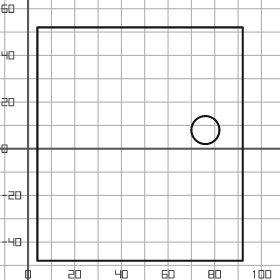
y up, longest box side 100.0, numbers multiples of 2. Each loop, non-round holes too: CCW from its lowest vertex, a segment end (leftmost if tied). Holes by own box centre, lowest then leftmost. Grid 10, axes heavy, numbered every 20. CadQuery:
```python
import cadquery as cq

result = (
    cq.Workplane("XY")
    .moveTo(4.0, -48.0)
    .lineTo(92.0, -48.0)
    .lineTo(92.0, 52.0)
    .lineTo(4.0, 52.0)
    .close()
    .moveTo(76.0, 8.0)
    .circle(6.0)
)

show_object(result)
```